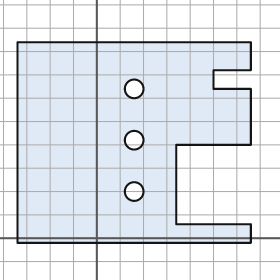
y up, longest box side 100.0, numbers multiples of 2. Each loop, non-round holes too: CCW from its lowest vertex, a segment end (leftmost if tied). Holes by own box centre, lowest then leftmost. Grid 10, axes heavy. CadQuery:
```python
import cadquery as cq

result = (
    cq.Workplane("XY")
    .moveTo(-34.0, -2.0)
    .lineTo(66.0, -2.0)
    .lineTo(66.0, 6.0)
    .lineTo(34.0, 6.0)
    .lineTo(34.0, 40.0)
    .lineTo(66.0, 40.0)
    .lineTo(66.0, 64.0)
    .lineTo(50.0, 64.0)
    .lineTo(50.0, 72.0)
    .lineTo(66.0, 72.0)
    .lineTo(66.0, 84.0)
    .lineTo(-34.0, 84.0)
    .close()
    .moveTo(16.0, 20.0)
    .circle(4.0)
    .moveTo(16.0, 42.0)
    .circle(4.0)
    .moveTo(16.0, 64.0)
    .circle(4.0)
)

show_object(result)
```